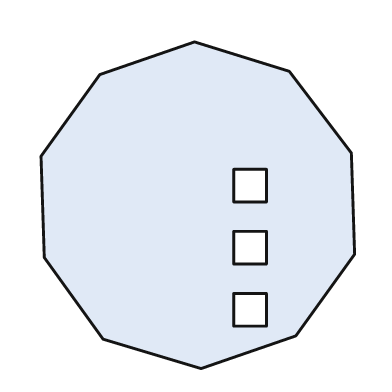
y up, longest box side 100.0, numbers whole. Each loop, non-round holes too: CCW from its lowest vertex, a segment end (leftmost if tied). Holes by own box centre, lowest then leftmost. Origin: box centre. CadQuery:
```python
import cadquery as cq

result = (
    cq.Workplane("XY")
    .moveTo(1.0, -50.0)
    .lineTo(30.0, -40.0)
    .lineTo(48.0, -15.0)
    .lineTo(47.0, 16.0)
    .lineTo(28.0, 41.0)
    .lineTo(-1.0, 50.0)
    .lineTo(-30.0, 40.0)
    .lineTo(-48.0, 15.0)
    .lineTo(-47.0, -16.0)
    .lineTo(-29.0, -41.0)
    .close()
    .moveTo(11.0, -37.0)
    .lineTo(21.0, -37.0)
    .lineTo(21.0, -27.0)
    .lineTo(11.0, -27.0)
    .close()
    .moveTo(11.0, -18.0)
    .lineTo(21.0, -18.0)
    .lineTo(21.0, -8.0)
    .lineTo(11.0, -8.0)
    .close()
    .moveTo(11.0, 1.0)
    .lineTo(21.0, 1.0)
    .lineTo(21.0, 11.0)
    .lineTo(11.0, 11.0)
    .close()
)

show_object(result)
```